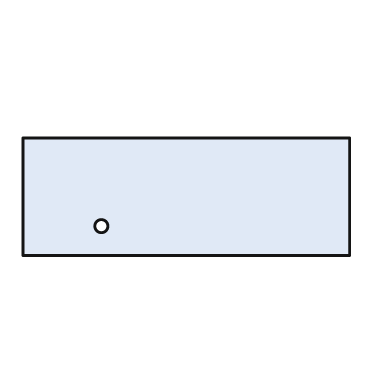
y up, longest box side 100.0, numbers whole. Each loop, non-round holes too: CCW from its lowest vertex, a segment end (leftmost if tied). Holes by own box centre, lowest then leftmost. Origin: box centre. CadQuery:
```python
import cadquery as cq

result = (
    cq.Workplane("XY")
    .moveTo(-50.0, -18.0)
    .lineTo(50.0, -18.0)
    .lineTo(50.0, 18.0)
    .lineTo(-50.0, 18.0)
    .close()
    .moveTo(-26.0, -9.0)
    .circle(2.0)
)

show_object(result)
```